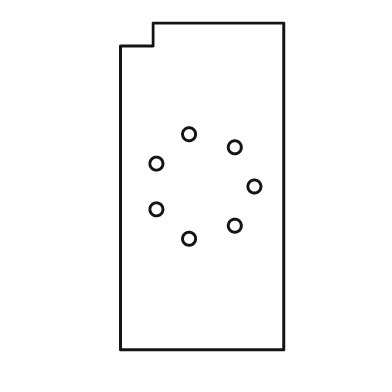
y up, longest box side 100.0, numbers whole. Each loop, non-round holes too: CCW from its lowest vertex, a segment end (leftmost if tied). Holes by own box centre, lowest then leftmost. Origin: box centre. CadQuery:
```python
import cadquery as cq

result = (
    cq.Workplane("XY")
    .moveTo(-25.0, -50.0)
    .lineTo(25.0, -50.0)
    .lineTo(25.0, 50.0)
    .lineTo(-15.0, 50.0)
    .lineTo(-15.0, 43.0)
    .lineTo(-25.0, 43.0)
    .close()
    .moveTo(-4.0, -16.0)
    .circle(2.0)
    .moveTo(10.0, -12.0)
    .circle(2.0)
    .moveTo(-14.0, -7.0)
    .circle(2.0)
    .moveTo(16.0, 0.0)
    .circle(2.0)
    .moveTo(-14.0, 7.0)
    .circle(2.0)
    .moveTo(10.0, 12.0)
    .circle(2.0)
    .moveTo(-4.0, 16.0)
    .circle(2.0)
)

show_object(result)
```